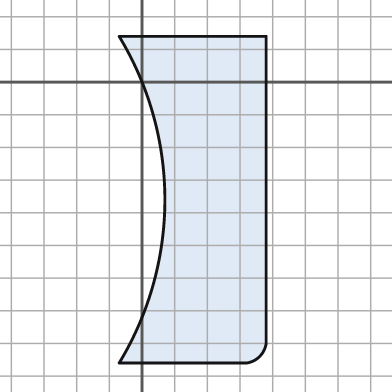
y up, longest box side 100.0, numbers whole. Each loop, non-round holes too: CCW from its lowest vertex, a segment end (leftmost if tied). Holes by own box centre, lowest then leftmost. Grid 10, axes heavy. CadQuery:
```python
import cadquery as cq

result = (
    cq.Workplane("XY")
    .moveTo(-7.0, -86.0)
    .lineTo(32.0, -86.0)
    .threePointArc((36.0, -84.0), (38.0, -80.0))
    .lineTo(38.0, 14.0)
    .lineTo(-7.0, 14.0)
    .threePointArc((7.0, -36.0), (-7.0, -86.0))
    .close()
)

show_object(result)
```